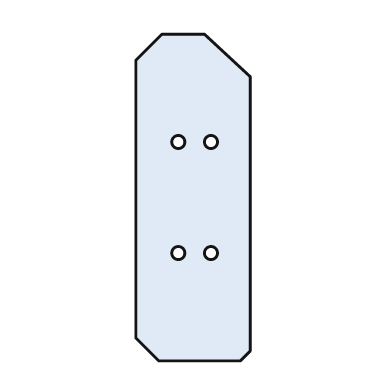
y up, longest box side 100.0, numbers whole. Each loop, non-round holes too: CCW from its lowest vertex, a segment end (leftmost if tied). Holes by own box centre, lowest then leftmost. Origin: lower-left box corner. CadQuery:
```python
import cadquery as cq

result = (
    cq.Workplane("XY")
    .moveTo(7.0, 0.0)
    .lineTo(32.0, 0.0)
    .lineTo(35.0, 3.0)
    .lineTo(35.0, 87.0)
    .lineTo(21.0, 100.0)
    .lineTo(8.0, 100.0)
    .lineTo(0.0, 92.0)
    .lineTo(0.0, 7.0)
    .close()
    .moveTo(13.0, 33.0)
    .circle(2.0)
    .moveTo(23.0, 33.0)
    .circle(2.0)
    .moveTo(13.0, 67.0)
    .circle(2.0)
    .moveTo(23.0, 67.0)
    .circle(2.0)
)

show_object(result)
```